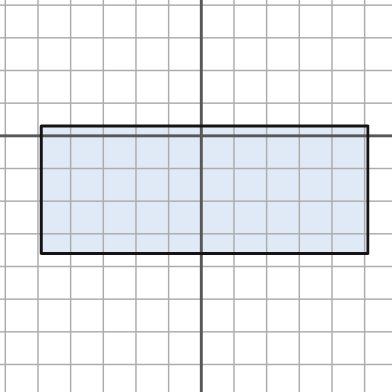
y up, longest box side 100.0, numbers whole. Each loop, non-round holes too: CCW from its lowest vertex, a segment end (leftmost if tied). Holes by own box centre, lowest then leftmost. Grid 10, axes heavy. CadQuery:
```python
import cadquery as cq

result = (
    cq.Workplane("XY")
    .moveTo(-49.0, -36.0)
    .lineTo(51.0, -36.0)
    .lineTo(51.0, 3.0)
    .lineTo(-49.0, 3.0)
    .close()
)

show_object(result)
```